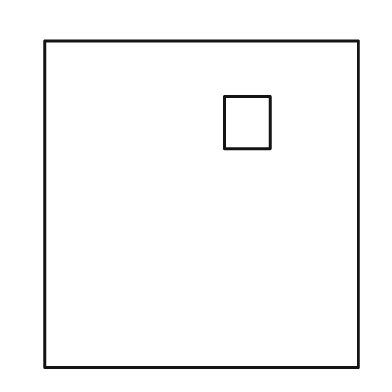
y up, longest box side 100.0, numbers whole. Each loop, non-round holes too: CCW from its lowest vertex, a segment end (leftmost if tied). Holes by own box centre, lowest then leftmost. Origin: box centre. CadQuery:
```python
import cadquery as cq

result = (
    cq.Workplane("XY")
    .moveTo(-48.0, -50.0)
    .lineTo(48.0, -50.0)
    .lineTo(48.0, 50.0)
    .lineTo(-48.0, 50.0)
    .close()
    .moveTo(7.0, 17.0)
    .lineTo(21.0, 17.0)
    .lineTo(21.0, 33.0)
    .lineTo(7.0, 33.0)
    .close()
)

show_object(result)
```